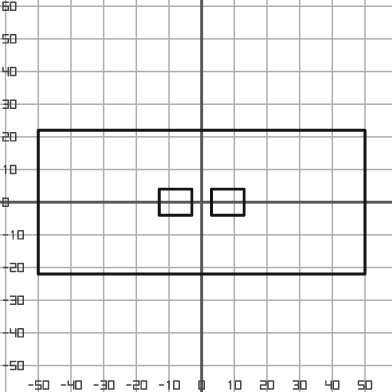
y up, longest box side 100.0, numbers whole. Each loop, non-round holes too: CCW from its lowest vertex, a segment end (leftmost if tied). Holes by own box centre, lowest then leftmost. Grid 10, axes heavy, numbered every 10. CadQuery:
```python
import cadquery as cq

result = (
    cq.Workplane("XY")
    .moveTo(-50.0, -22.0)
    .lineTo(50.0, -22.0)
    .lineTo(50.0, 22.0)
    .lineTo(-50.0, 22.0)
    .close()
    .moveTo(-13.0, -4.0)
    .lineTo(-3.0, -4.0)
    .lineTo(-3.0, 4.0)
    .lineTo(-13.0, 4.0)
    .close()
    .moveTo(3.0, -4.0)
    .lineTo(13.0, -4.0)
    .lineTo(13.0, 4.0)
    .lineTo(3.0, 4.0)
    .close()
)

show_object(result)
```